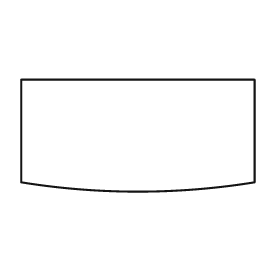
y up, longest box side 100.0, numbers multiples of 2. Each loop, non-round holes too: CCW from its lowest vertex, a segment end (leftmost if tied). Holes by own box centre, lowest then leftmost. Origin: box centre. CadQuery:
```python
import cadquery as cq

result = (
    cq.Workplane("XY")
    .moveTo(-50.0, -20.0)
    .threePointArc((0.0, -24.0), (50.0, -20.0))
    .lineTo(50.0, 24.0)
    .lineTo(-50.0, 24.0)
    .close()
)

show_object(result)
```